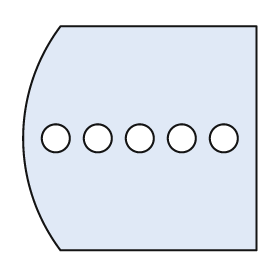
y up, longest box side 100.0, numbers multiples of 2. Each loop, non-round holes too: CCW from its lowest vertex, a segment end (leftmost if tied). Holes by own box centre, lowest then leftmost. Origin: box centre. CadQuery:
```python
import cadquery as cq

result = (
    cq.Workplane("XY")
    .moveTo(-34.0, -48.0)
    .lineTo(50.0, -48.0)
    .lineTo(50.0, 48.0)
    .lineTo(-34.0, 48.0)
    .threePointArc((-50.0, 0.0), (-34.0, -48.0))
    .close()
    .moveTo(-36.0, 0.0)
    .circle(6.0)
    .moveTo(-18.0, 0.0)
    .circle(6.0)
    .moveTo(0.0, 0.0)
    .circle(6.0)
    .moveTo(18.0, 0.0)
    .circle(6.0)
    .moveTo(36.0, 0.0)
    .circle(6.0)
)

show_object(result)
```